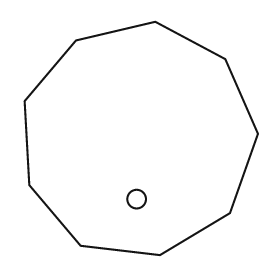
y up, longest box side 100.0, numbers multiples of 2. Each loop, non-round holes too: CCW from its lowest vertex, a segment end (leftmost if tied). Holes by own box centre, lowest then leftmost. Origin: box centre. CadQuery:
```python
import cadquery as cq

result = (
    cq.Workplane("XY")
    .moveTo(8.0, -50.0)
    .lineTo(38.0, -32.0)
    .lineTo(50.0, 2.0)
    .lineTo(36.0, 34.0)
    .lineTo(6.0, 50.0)
    .lineTo(-28.0, 42.0)
    .lineTo(-50.0, 16.0)
    .lineTo(-48.0, -20.0)
    .lineTo(-26.0, -46.0)
    .close()
    .moveTo(-2.0, -26.0)
    .circle(4.0)
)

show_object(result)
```